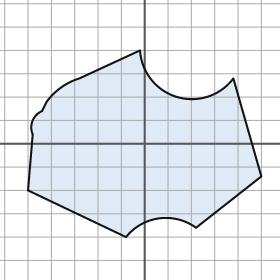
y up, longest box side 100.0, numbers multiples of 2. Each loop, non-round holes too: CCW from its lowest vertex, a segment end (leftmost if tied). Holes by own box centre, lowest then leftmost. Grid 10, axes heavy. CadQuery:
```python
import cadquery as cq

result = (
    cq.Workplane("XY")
    .moveTo(-8.0, -40.0)
    .threePointArc((6.0, -32.0), (22.0, -36.0))
    .lineTo(50.0, -14.0)
    .lineTo(38.0, 28.0)
    .threePointArc((14.0, 20.0), (-2.0, 40.0))
    .lineTo(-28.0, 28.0)
    .threePointArc((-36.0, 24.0), (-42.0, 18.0))
    .lineTo(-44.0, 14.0)
    .threePointArc((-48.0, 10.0), (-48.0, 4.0))
    .lineTo(-50.0, -20.0)
    .close()
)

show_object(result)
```